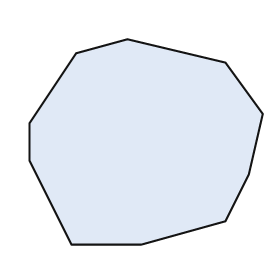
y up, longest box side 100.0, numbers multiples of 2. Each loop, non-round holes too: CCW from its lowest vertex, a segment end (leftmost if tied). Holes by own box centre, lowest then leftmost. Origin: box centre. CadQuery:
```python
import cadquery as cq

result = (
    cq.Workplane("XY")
    .moveTo(-32.0, -44.0)
    .lineTo(-2.0, -44.0)
    .lineTo(34.0, -34.0)
    .lineTo(44.0, -14.0)
    .lineTo(50.0, 12.0)
    .lineTo(34.0, 34.0)
    .lineTo(-8.0, 44.0)
    .lineTo(-30.0, 38.0)
    .lineTo(-50.0, 8.0)
    .lineTo(-50.0, -8.0)
    .close()
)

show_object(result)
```